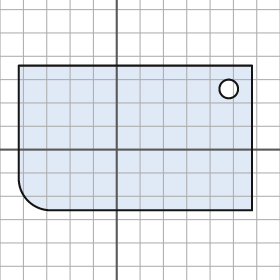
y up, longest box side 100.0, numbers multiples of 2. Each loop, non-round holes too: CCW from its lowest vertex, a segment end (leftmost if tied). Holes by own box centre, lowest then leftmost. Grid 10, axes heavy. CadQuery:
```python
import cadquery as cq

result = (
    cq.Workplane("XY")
    .moveTo(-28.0, -26.0)
    .lineTo(58.0, -26.0)
    .lineTo(58.0, 36.0)
    .lineTo(-42.0, 36.0)
    .lineTo(-42.0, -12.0)
    .threePointArc((-38.0, -22.0), (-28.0, -26.0))
    .close()
    .moveTo(48.0, 26.0)
    .circle(4.0)
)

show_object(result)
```